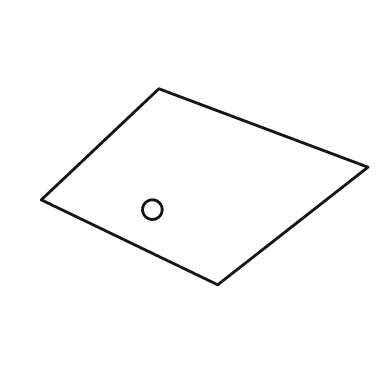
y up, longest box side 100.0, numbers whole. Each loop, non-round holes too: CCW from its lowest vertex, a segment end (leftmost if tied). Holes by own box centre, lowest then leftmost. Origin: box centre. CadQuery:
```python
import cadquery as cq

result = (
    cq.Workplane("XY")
    .moveTo(4.0, -30.0)
    .lineTo(50.0, 6.0)
    .lineTo(-14.0, 30.0)
    .lineTo(-50.0, -4.0)
    .close()
    .moveTo(-16.0, -7.0)
    .circle(3.0)
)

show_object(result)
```